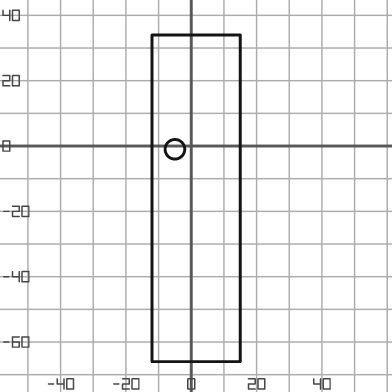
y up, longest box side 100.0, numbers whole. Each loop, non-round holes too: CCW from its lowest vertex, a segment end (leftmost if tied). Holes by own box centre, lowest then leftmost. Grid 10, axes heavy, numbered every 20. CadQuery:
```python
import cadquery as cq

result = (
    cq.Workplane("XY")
    .moveTo(-12.0, -66.0)
    .lineTo(15.0, -66.0)
    .lineTo(15.0, 34.0)
    .lineTo(-12.0, 34.0)
    .close()
    .moveTo(-5.0, -1.0)
    .circle(3.0)
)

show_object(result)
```